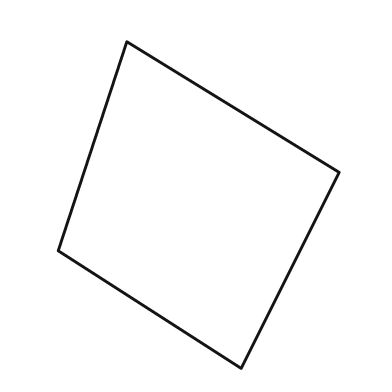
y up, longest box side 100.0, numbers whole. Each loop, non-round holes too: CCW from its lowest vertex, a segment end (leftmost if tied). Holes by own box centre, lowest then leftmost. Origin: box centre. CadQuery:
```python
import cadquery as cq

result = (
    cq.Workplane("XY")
    .moveTo(13.0, -50.0)
    .lineTo(43.0, 10.0)
    .lineTo(-22.0, 50.0)
    .lineTo(-43.0, -14.0)
    .close()
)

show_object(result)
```